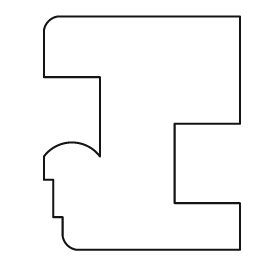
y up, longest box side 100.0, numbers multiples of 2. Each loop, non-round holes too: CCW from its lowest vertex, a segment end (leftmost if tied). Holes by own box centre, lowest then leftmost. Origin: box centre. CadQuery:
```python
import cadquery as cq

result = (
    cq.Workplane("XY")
    .moveTo(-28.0, -50.0)
    .lineTo(42.0, -50.0)
    .lineTo(42.0, -30.0)
    .lineTo(14.0, -30.0)
    .lineTo(14.0, 4.0)
    .lineTo(42.0, 4.0)
    .lineTo(42.0, 50.0)
    .lineTo(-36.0, 50.0)
    .threePointArc((-40.0, 48.0), (-42.0, 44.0))
    .lineTo(-42.0, 24.0)
    .lineTo(-18.0, 24.0)
    .lineTo(-18.0, -10.0)
    .threePointArc((-30.0, -4.0), (-42.0, -10.0))
    .lineTo(-42.0, -20.0)
    .lineTo(-38.0, -20.0)
    .lineTo(-38.0, -36.0)
    .lineTo(-34.0, -36.0)
    .lineTo(-34.0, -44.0)
    .threePointArc((-32.0, -48.0), (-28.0, -50.0))
    .close()
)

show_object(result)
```